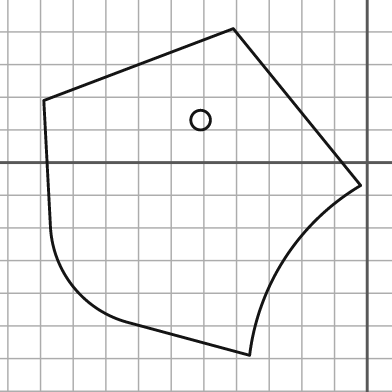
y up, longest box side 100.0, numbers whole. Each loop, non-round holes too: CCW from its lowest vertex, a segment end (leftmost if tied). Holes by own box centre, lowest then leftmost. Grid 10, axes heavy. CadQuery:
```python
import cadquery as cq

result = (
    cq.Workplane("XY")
    .moveTo(-36.0, -59.0)
    .threePointArc((-25.0, -29.0), (-2.0, -7.0))
    .lineTo(-41.0, 41.0)
    .lineTo(-99.0, 19.0)
    .lineTo(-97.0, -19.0)
    .threePointArc((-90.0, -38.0), (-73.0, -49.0))
    .close()
    .moveTo(-51.0, 13.0)
    .circle(3.0)
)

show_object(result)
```